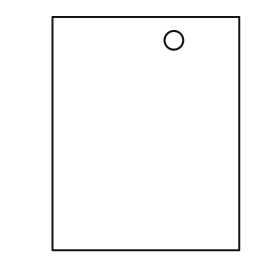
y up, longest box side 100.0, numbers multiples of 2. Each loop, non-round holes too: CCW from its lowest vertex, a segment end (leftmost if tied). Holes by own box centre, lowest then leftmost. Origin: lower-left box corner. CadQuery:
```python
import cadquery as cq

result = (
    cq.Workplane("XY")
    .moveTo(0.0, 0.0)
    .lineTo(80.0, 0.0)
    .lineTo(80.0, 100.0)
    .lineTo(0.0, 100.0)
    .close()
    .moveTo(52.0, 90.0)
    .circle(4.0)
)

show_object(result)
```